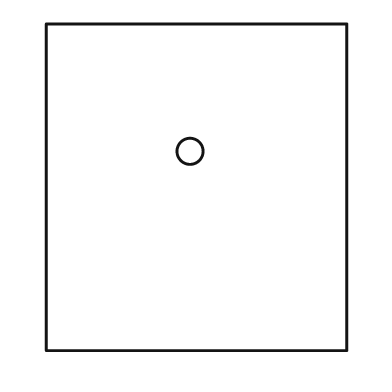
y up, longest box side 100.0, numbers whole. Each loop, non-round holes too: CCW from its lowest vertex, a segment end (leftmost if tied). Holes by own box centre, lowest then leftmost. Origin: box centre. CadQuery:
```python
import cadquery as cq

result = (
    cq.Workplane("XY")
    .moveTo(-46.0, -50.0)
    .lineTo(46.0, -50.0)
    .lineTo(46.0, 50.0)
    .lineTo(-46.0, 50.0)
    .close()
    .moveTo(-2.0, 11.0)
    .circle(4.0)
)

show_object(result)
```